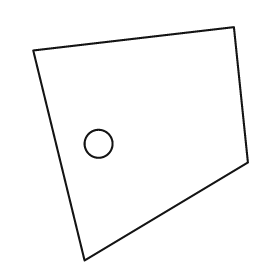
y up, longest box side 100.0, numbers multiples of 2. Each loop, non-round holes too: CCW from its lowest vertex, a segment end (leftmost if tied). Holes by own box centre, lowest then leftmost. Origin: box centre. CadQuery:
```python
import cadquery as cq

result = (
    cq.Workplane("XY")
    .moveTo(-24.0, -50.0)
    .lineTo(46.0, -8.0)
    .lineTo(40.0, 50.0)
    .lineTo(-46.0, 40.0)
    .close()
    .moveTo(-18.0, 0.0)
    .circle(6.0)
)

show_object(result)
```